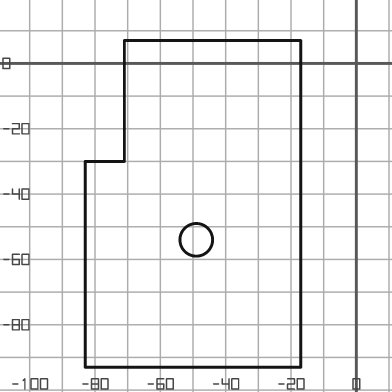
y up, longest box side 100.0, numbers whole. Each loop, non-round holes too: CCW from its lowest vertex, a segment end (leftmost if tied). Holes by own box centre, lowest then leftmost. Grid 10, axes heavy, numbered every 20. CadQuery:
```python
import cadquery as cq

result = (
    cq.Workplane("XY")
    .moveTo(-83.0, -93.0)
    .lineTo(-17.0, -93.0)
    .lineTo(-17.0, 7.0)
    .lineTo(-71.0, 7.0)
    .lineTo(-71.0, -30.0)
    .lineTo(-83.0, -30.0)
    .close()
    .moveTo(-49.0, -54.0)
    .circle(5.0)
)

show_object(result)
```